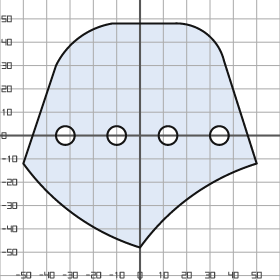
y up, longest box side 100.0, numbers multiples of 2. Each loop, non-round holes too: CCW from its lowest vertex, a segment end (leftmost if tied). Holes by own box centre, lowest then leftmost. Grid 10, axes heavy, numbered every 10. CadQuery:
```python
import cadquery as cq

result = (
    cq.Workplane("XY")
    .moveTo(0.0, -48.0)
    .threePointArc((22.0, -26.0), (50.0, -12.0))
    .lineTo(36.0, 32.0)
    .threePointArc((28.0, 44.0), (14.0, 48.0))
    .lineTo(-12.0, 48.0)
    .threePointArc((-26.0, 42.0), (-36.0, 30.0))
    .lineTo(-50.0, -12.0)
    .threePointArc((-28.0, -34.0), (0.0, -48.0))
    .close()
    .moveTo(-32.0, 0.0)
    .circle(4.0)
    .moveTo(-10.0, 0.0)
    .circle(4.0)
    .moveTo(12.0, 0.0)
    .circle(4.0)
    .moveTo(34.0, 0.0)
    .circle(4.0)
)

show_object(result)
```